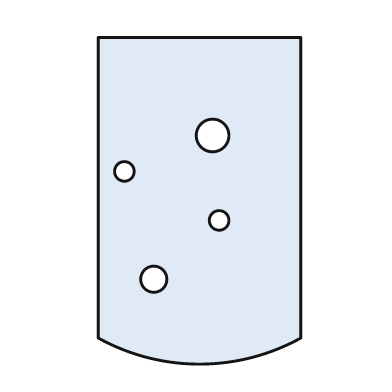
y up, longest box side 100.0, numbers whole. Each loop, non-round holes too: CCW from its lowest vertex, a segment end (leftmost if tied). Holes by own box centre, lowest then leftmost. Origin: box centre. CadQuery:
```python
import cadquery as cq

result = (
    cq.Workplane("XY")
    .moveTo(-31.0, -42.0)
    .threePointArc((0.0, -50.0), (31.0, -42.0))
    .lineTo(31.0, 50.0)
    .lineTo(-31.0, 50.0)
    .close()
    .moveTo(-14.0, -24.0)
    .circle(4.0)
    .moveTo(6.0, -6.0)
    .circle(3.0)
    .moveTo(-23.0, 9.0)
    .circle(3.0)
    .moveTo(4.0, 20.0)
    .circle(5.0)
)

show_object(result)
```